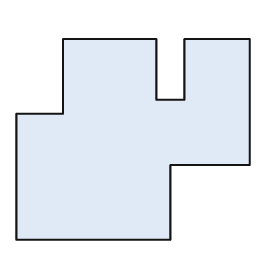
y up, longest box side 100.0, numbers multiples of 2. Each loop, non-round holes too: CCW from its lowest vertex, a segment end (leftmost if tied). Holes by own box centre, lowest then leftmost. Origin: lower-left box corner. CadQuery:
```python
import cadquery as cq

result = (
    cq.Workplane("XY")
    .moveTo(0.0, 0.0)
    .lineTo(66.0, 0.0)
    .lineTo(66.0, 32.0)
    .lineTo(100.0, 32.0)
    .lineTo(100.0, 86.0)
    .lineTo(72.0, 86.0)
    .lineTo(72.0, 60.0)
    .lineTo(60.0, 60.0)
    .lineTo(60.0, 86.0)
    .lineTo(20.0, 86.0)
    .lineTo(20.0, 54.0)
    .lineTo(0.0, 54.0)
    .close()
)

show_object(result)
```